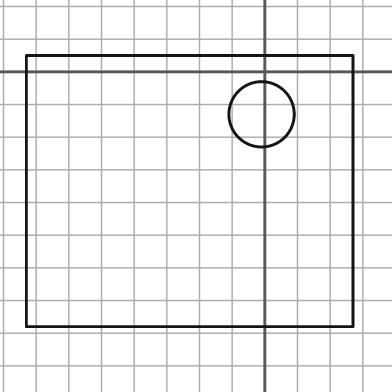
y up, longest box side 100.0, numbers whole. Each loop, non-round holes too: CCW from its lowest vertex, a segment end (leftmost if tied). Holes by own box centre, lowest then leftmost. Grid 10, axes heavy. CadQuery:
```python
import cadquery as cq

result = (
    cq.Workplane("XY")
    .moveTo(-73.0, -78.0)
    .lineTo(27.0, -78.0)
    .lineTo(27.0, 5.0)
    .lineTo(-73.0, 5.0)
    .close()
    .moveTo(-1.0, -13.0)
    .circle(10.0)
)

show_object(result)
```